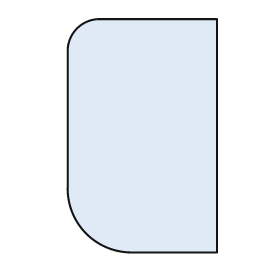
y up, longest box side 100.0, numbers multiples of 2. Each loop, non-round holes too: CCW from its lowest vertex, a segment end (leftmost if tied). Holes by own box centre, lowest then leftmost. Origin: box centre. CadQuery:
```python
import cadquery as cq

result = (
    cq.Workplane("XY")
    .moveTo(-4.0, -50.0)
    .lineTo(32.0, -50.0)
    .lineTo(32.0, 50.0)
    .lineTo(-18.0, 50.0)
    .threePointArc((-28.0, 46.0), (-32.0, 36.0))
    .lineTo(-32.0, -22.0)
    .threePointArc((-24.0, -42.0), (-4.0, -50.0))
    .close()
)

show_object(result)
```